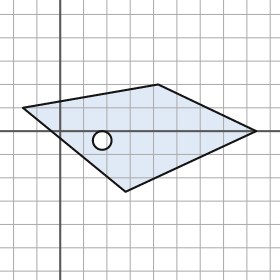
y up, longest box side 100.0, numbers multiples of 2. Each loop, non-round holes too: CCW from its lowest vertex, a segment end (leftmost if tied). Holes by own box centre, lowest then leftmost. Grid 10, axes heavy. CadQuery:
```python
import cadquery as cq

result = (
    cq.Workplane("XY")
    .moveTo(28.0, -26.0)
    .lineTo(84.0, 0.0)
    .lineTo(42.0, 20.0)
    .lineTo(-16.0, 10.0)
    .close()
    .moveTo(18.0, -4.0)
    .circle(4.0)
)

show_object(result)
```